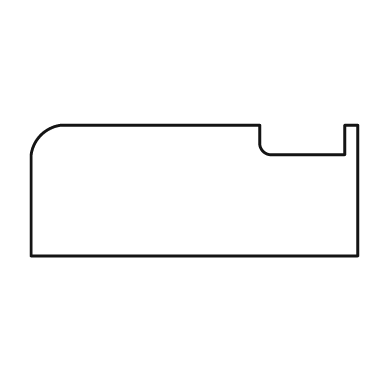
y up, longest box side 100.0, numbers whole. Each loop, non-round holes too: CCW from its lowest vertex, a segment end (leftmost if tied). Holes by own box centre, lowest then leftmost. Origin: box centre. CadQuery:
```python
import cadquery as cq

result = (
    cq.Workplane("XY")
    .moveTo(-50.0, -20.0)
    .lineTo(50.0, -20.0)
    .lineTo(50.0, 20.0)
    .lineTo(46.0, 20.0)
    .lineTo(46.0, 11.0)
    .lineTo(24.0, 11.0)
    .threePointArc((21.0, 12.0), (20.0, 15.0))
    .lineTo(20.0, 20.0)
    .lineTo(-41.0, 20.0)
    .threePointArc((-47.0, 17.0), (-50.0, 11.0))
    .close()
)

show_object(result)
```